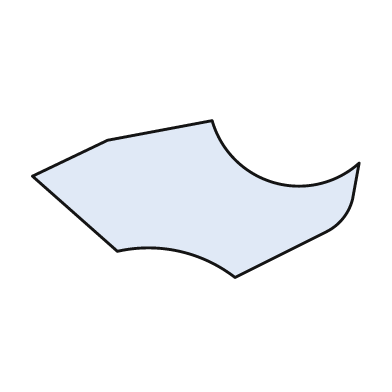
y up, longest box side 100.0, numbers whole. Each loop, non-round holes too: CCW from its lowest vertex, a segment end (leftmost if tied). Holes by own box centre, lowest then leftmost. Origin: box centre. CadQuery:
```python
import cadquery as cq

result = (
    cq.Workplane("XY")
    .moveTo(12.0, -24.0)
    .lineTo(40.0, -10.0)
    .threePointArc((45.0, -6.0), (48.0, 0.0))
    .lineTo(50.0, 11.0)
    .threePointArc((24.0, 5.0), (5.0, 24.0))
    .lineTo(-27.0, 18.0)
    .lineTo(-50.0, 7.0)
    .lineTo(-24.0, -16.0)
    .threePointArc((-5.0, -16.0), (12.0, -24.0))
    .close()
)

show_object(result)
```